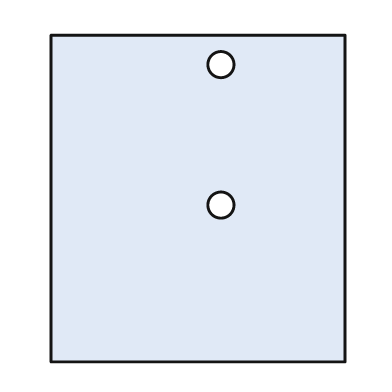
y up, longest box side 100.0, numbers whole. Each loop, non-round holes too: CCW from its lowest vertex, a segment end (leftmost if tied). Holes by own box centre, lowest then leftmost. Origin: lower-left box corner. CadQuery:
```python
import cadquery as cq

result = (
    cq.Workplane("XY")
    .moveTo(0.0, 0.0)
    .lineTo(90.0, 0.0)
    .lineTo(90.0, 100.0)
    .lineTo(0.0, 100.0)
    .close()
    .moveTo(52.0, 48.0)
    .circle(4.0)
    .moveTo(52.0, 91.0)
    .circle(4.0)
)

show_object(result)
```